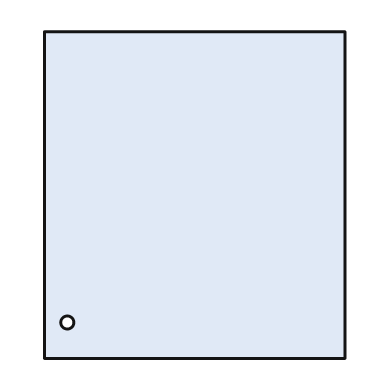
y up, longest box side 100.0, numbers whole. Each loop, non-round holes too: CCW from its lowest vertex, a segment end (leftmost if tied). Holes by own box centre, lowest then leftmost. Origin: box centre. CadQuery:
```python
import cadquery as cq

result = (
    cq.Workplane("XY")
    .moveTo(-46.0, -50.0)
    .lineTo(46.0, -50.0)
    .lineTo(46.0, 50.0)
    .lineTo(-46.0, 50.0)
    .close()
    .moveTo(-39.0, -39.0)
    .circle(2.0)
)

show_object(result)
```